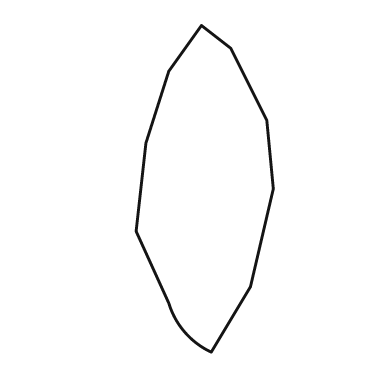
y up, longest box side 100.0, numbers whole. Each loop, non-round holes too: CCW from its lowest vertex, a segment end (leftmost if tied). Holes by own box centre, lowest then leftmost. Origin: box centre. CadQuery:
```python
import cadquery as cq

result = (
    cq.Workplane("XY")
    .moveTo(2.0, -50.0)
    .lineTo(14.0, -30.0)
    .lineTo(21.0, 0.0)
    .lineTo(19.0, 21.0)
    .lineTo(8.0, 43.0)
    .lineTo(-1.0, 50.0)
    .lineTo(-11.0, 36.0)
    .lineTo(-18.0, 14.0)
    .lineTo(-21.0, -13.0)
    .lineTo(-11.0, -35.0)
    .threePointArc((-6.0, -44.0), (2.0, -50.0))
    .close()
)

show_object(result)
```